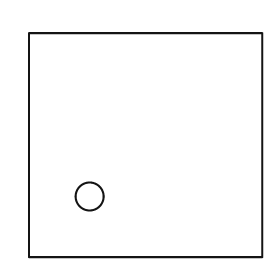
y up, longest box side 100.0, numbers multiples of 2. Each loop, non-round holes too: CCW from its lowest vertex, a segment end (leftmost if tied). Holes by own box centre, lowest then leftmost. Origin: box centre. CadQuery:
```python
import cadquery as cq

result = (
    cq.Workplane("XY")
    .moveTo(-50.0, -48.0)
    .lineTo(50.0, -48.0)
    .lineTo(50.0, 48.0)
    .lineTo(-50.0, 48.0)
    .close()
    .moveTo(-24.0, -22.0)
    .circle(6.0)
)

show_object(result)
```